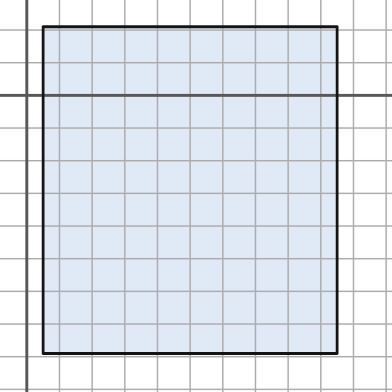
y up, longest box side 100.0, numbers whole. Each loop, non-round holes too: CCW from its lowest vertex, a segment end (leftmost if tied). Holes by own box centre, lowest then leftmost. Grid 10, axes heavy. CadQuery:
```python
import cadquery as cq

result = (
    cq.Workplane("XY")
    .moveTo(5.0, -79.0)
    .lineTo(95.0, -79.0)
    .lineTo(95.0, 21.0)
    .lineTo(5.0, 21.0)
    .close()
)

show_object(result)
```